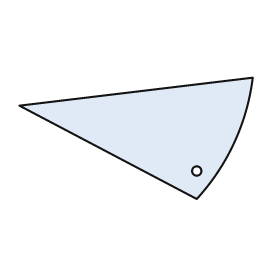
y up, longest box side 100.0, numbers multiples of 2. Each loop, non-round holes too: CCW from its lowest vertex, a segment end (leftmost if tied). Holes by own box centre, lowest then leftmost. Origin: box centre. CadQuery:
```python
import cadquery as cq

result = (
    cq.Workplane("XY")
    .moveTo(26.0, -26.0)
    .threePointArc((42.0, -2.0), (50.0, 26.0))
    .lineTo(-50.0, 14.0)
    .close()
    .moveTo(26.0, -14.0)
    .circle(2.0)
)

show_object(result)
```